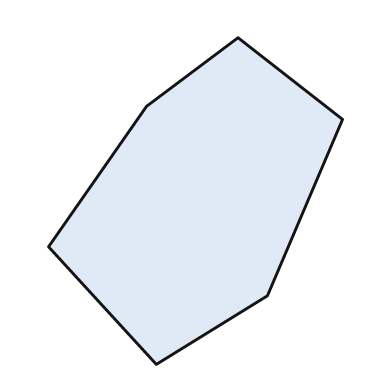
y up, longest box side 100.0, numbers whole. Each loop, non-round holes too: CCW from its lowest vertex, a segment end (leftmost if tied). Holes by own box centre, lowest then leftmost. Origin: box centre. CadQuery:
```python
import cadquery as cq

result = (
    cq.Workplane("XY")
    .moveTo(-12.0, -50.0)
    .lineTo(22.0, -29.0)
    .lineTo(45.0, 25.0)
    .lineTo(13.0, 50.0)
    .lineTo(-15.0, 29.0)
    .lineTo(-45.0, -14.0)
    .close()
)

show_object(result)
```